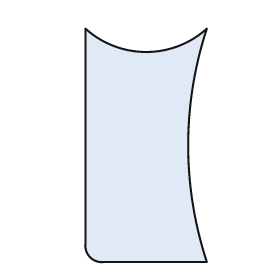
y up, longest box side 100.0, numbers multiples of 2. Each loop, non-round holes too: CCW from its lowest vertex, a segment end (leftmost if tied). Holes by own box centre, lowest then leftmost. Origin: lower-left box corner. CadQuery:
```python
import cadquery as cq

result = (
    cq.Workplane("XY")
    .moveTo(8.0, 0.0)
    .lineTo(52.0, 0.0)
    .threePointArc((44.0, 50.0), (52.0, 100.0))
    .threePointArc((26.0, 90.0), (0.0, 100.0))
    .lineTo(0.0, 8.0)
    .threePointArc((2.0, 2.0), (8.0, 0.0))
    .close()
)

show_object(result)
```